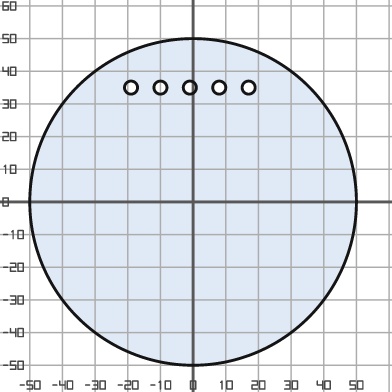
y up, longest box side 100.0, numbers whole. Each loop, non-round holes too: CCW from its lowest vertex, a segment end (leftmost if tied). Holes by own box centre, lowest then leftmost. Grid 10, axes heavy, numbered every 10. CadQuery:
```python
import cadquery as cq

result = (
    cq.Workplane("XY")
    .moveTo(0.0, 0.0)
    .circle(50.0)
    .moveTo(-19.0, 35.0)
    .circle(2.0)
    .moveTo(-10.0, 35.0)
    .circle(2.0)
    .moveTo(-1.0, 35.0)
    .circle(2.0)
    .moveTo(8.0, 35.0)
    .circle(2.0)
    .moveTo(17.0, 35.0)
    .circle(2.0)
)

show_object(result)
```